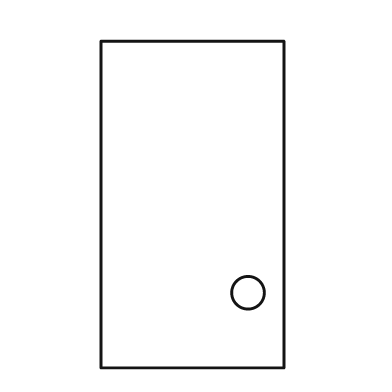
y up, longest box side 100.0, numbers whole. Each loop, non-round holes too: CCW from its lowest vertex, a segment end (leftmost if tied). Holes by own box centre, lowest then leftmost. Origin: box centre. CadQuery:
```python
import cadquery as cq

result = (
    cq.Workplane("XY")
    .moveTo(-28.0, -50.0)
    .lineTo(28.0, -50.0)
    .lineTo(28.0, 50.0)
    .lineTo(-28.0, 50.0)
    .close()
    .moveTo(17.0, -27.0)
    .circle(5.0)
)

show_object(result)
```